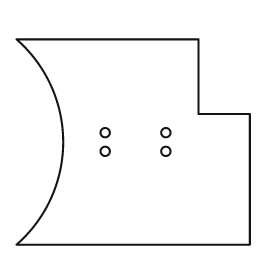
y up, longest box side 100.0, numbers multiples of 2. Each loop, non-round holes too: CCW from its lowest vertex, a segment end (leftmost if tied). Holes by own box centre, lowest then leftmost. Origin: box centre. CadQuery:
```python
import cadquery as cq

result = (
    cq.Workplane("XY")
    .moveTo(-50.0, -44.0)
    .lineTo(50.0, -44.0)
    .lineTo(50.0, 12.0)
    .lineTo(28.0, 12.0)
    .lineTo(28.0, 44.0)
    .lineTo(-50.0, 44.0)
    .threePointArc((-30.0, 0.0), (-50.0, -44.0))
    .close()
    .moveTo(-12.0, -4.0)
    .circle(2.0)
    .moveTo(14.0, -4.0)
    .circle(2.0)
    .moveTo(-12.0, 4.0)
    .circle(2.0)
    .moveTo(14.0, 4.0)
    .circle(2.0)
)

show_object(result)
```